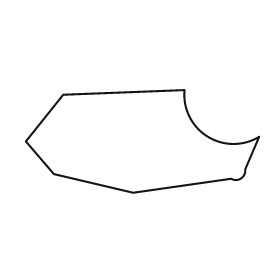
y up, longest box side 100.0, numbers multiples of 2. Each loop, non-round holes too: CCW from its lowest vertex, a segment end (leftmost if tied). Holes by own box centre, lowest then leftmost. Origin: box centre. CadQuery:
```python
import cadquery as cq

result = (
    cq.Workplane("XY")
    .moveTo(-4.0, -22.0)
    .lineTo(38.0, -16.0)
    .threePointArc((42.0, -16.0), (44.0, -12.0))
    .lineTo(50.0, 2.0)
    .threePointArc((28.0, 2.0), (18.0, 22.0))
    .lineTo(-34.0, 20.0)
    .lineTo(-50.0, 0.0)
    .lineTo(-38.0, -14.0)
    .close()
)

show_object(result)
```